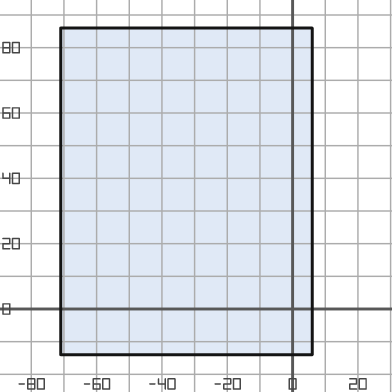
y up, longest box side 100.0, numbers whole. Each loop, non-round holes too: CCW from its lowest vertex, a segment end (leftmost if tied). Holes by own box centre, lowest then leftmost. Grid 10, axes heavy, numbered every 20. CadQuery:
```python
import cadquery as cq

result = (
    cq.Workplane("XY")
    .moveTo(-71.0, -14.0)
    .lineTo(6.0, -14.0)
    .lineTo(6.0, 86.0)
    .lineTo(-71.0, 86.0)
    .close()
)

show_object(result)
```